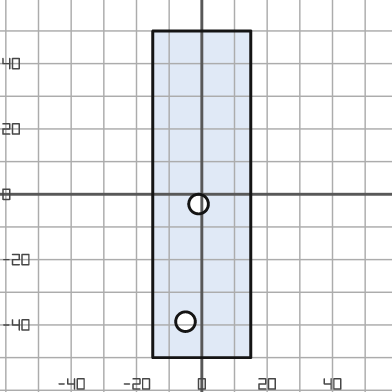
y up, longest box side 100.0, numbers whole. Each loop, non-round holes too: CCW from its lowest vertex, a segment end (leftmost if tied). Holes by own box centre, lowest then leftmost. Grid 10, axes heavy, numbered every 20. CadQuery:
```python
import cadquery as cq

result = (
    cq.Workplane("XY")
    .moveTo(-15.0, -50.0)
    .lineTo(15.0, -50.0)
    .lineTo(15.0, 50.0)
    .lineTo(-15.0, 50.0)
    .close()
    .moveTo(-5.0, -39.0)
    .circle(3.0)
    .moveTo(-1.0, -3.0)
    .circle(3.0)
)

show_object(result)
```